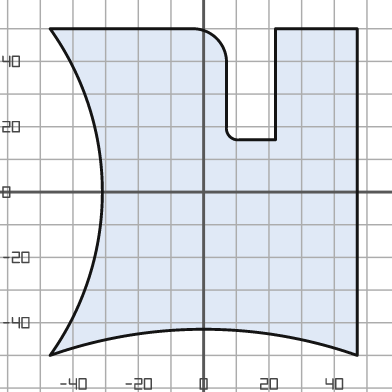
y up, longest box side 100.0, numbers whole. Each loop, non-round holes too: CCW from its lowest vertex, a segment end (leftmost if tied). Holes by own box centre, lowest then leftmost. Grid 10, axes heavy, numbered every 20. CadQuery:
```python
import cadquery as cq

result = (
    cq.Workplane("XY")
    .moveTo(-47.0, -50.0)
    .threePointArc((0.0, -42.0), (47.0, -50.0))
    .lineTo(47.0, 50.0)
    .lineTo(22.0, 50.0)
    .lineTo(22.0, 16.0)
    .lineTo(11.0, 16.0)
    .threePointArc((8.0, 17.0), (7.0, 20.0))
    .lineTo(7.0, 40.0)
    .threePointArc((4.0, 47.0), (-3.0, 50.0))
    .lineTo(-47.0, 50.0)
    .threePointArc((-31.0, 0.0), (-47.0, -50.0))
    .close()
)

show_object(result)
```